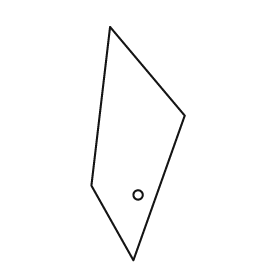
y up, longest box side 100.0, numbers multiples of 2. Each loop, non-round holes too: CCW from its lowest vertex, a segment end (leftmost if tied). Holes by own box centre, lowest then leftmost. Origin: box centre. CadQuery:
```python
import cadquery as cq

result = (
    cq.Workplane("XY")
    .moveTo(-2.0, -50.0)
    .lineTo(20.0, 12.0)
    .lineTo(-12.0, 50.0)
    .lineTo(-20.0, -18.0)
    .close()
    .moveTo(0.0, -22.0)
    .circle(2.0)
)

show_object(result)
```